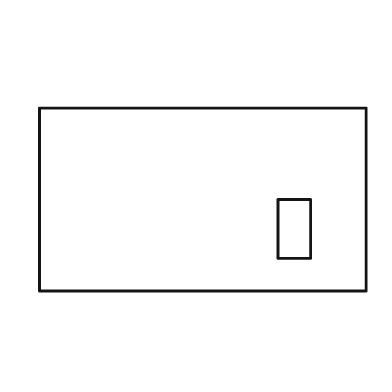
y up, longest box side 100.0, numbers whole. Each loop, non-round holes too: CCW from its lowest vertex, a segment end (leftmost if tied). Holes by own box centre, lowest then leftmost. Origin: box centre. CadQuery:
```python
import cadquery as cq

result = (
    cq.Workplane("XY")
    .moveTo(-50.0, -28.0)
    .lineTo(50.0, -28.0)
    .lineTo(50.0, 28.0)
    .lineTo(-50.0, 28.0)
    .close()
    .moveTo(23.0, -18.0)
    .lineTo(33.0, -18.0)
    .lineTo(33.0, 0.0)
    .lineTo(23.0, 0.0)
    .close()
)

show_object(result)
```